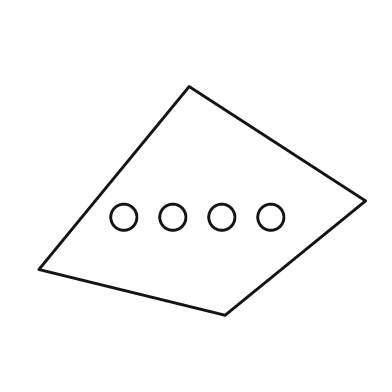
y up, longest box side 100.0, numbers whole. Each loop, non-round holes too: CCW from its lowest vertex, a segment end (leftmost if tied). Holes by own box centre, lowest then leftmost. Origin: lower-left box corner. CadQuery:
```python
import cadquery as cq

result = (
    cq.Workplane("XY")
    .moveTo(57.0, 0.0)
    .lineTo(100.0, 35.0)
    .lineTo(46.0, 70.0)
    .lineTo(0.0, 14.0)
    .close()
    .moveTo(26.0, 30.0)
    .circle(4.0)
    .moveTo(41.0, 30.0)
    .circle(4.0)
    .moveTo(56.0, 30.0)
    .circle(4.0)
    .moveTo(71.0, 30.0)
    .circle(4.0)
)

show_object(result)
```